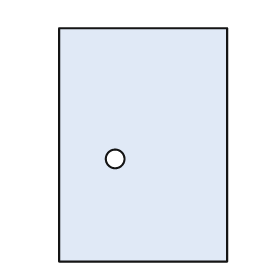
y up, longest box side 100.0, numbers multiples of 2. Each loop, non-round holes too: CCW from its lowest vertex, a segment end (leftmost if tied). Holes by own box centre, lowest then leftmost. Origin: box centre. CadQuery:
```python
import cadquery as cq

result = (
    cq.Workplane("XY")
    .moveTo(-36.0, -50.0)
    .lineTo(36.0, -50.0)
    .lineTo(36.0, 50.0)
    .lineTo(-36.0, 50.0)
    .close()
    .moveTo(-12.0, -6.0)
    .circle(4.0)
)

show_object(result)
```